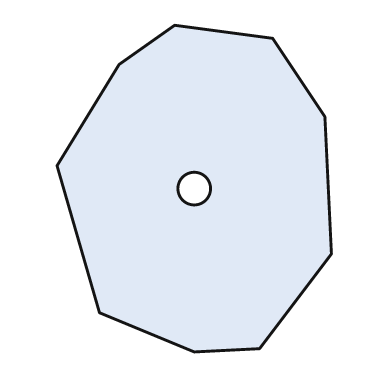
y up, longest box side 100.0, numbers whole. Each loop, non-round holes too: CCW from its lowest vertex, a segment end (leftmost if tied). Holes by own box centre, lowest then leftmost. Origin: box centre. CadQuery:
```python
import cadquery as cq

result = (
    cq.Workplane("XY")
    .moveTo(0.0, -50.0)
    .lineTo(20.0, -49.0)
    .lineTo(42.0, -20.0)
    .lineTo(40.0, 22.0)
    .lineTo(24.0, 46.0)
    .lineTo(-6.0, 50.0)
    .lineTo(-23.0, 38.0)
    .lineTo(-42.0, 7.0)
    .lineTo(-29.0, -38.0)
    .close()
    .moveTo(0.0, 0.0)
    .circle(5.0)
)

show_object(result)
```